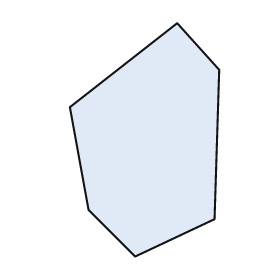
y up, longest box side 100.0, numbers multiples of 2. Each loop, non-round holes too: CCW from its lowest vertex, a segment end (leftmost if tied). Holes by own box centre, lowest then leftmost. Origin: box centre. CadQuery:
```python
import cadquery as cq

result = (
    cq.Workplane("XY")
    .moveTo(-4.0, -50.0)
    .lineTo(30.0, -34.0)
    .lineTo(32.0, 30.0)
    .lineTo(14.0, 50.0)
    .lineTo(-32.0, 14.0)
    .lineTo(-24.0, -30.0)
    .close()
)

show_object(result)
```